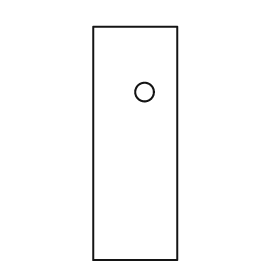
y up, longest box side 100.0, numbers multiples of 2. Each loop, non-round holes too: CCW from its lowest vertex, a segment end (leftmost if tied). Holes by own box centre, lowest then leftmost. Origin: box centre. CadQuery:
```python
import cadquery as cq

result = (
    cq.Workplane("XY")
    .moveTo(-18.0, -50.0)
    .lineTo(18.0, -50.0)
    .lineTo(18.0, 50.0)
    .lineTo(-18.0, 50.0)
    .close()
    .moveTo(4.0, 22.0)
    .circle(4.0)
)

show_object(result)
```